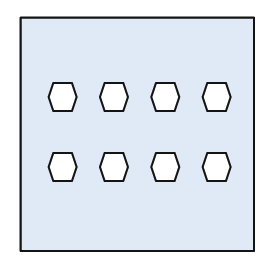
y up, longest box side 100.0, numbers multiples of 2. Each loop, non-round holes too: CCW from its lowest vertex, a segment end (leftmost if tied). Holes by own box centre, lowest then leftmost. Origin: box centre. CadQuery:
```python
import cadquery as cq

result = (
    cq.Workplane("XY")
    .moveTo(-50.0, -50.0)
    .lineTo(50.0, -50.0)
    .lineTo(50.0, 50.0)
    .lineTo(-50.0, 50.0)
    .close()
    .moveTo(-36.0, -20.0)
    .lineTo(-28.0, -20.0)
    .lineTo(-26.0, -14.0)
    .lineTo(-28.0, -8.0)
    .lineTo(-36.0, -8.0)
    .lineTo(-38.0, -14.0)
    .close()
    .moveTo(-14.0, -20.0)
    .lineTo(-6.0, -20.0)
    .lineTo(-4.0, -14.0)
    .lineTo(-6.0, -8.0)
    .lineTo(-14.0, -8.0)
    .lineTo(-16.0, -14.0)
    .close()
    .moveTo(8.0, -20.0)
    .lineTo(16.0, -20.0)
    .lineTo(18.0, -14.0)
    .lineTo(16.0, -8.0)
    .lineTo(8.0, -8.0)
    .lineTo(6.0, -14.0)
    .close()
    .moveTo(30.0, -20.0)
    .lineTo(38.0, -20.0)
    .lineTo(40.0, -14.0)
    .lineTo(38.0, -8.0)
    .lineTo(30.0, -8.0)
    .lineTo(28.0, -14.0)
    .close()
    .moveTo(-36.0, 10.0)
    .lineTo(-28.0, 10.0)
    .lineTo(-26.0, 16.0)
    .lineTo(-28.0, 22.0)
    .lineTo(-36.0, 22.0)
    .lineTo(-38.0, 16.0)
    .close()
    .moveTo(-14.0, 10.0)
    .lineTo(-6.0, 10.0)
    .lineTo(-4.0, 16.0)
    .lineTo(-6.0, 22.0)
    .lineTo(-14.0, 22.0)
    .lineTo(-16.0, 16.0)
    .close()
    .moveTo(8.0, 10.0)
    .lineTo(16.0, 10.0)
    .lineTo(18.0, 16.0)
    .lineTo(16.0, 22.0)
    .lineTo(8.0, 22.0)
    .lineTo(6.0, 16.0)
    .close()
    .moveTo(30.0, 10.0)
    .lineTo(38.0, 10.0)
    .lineTo(40.0, 16.0)
    .lineTo(38.0, 22.0)
    .lineTo(30.0, 22.0)
    .lineTo(28.0, 16.0)
    .close()
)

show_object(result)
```